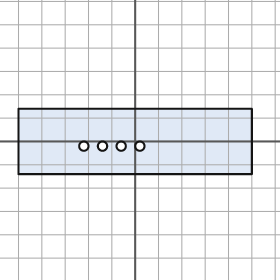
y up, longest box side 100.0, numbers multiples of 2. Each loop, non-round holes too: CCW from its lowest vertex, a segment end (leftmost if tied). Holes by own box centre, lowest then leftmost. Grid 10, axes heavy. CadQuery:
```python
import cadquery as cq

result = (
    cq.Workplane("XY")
    .moveTo(-50.0, -14.0)
    .lineTo(50.0, -14.0)
    .lineTo(50.0, 14.0)
    .lineTo(-50.0, 14.0)
    .close()
    .moveTo(-22.0, -2.0)
    .circle(2.0)
    .moveTo(-14.0, -2.0)
    .circle(2.0)
    .moveTo(-6.0, -2.0)
    .circle(2.0)
    .moveTo(2.0, -2.0)
    .circle(2.0)
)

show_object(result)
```